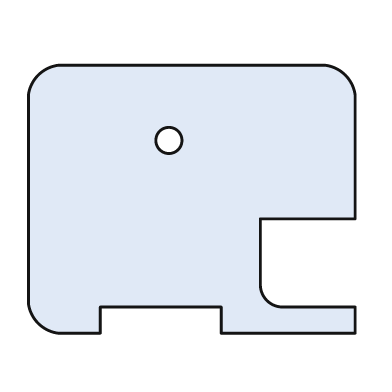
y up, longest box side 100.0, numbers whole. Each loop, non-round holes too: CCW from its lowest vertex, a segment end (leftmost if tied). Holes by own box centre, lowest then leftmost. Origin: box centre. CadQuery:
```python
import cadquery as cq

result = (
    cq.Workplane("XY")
    .moveTo(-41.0, -41.0)
    .lineTo(-28.0, -41.0)
    .lineTo(-28.0, -33.0)
    .lineTo(9.0, -33.0)
    .lineTo(9.0, -41.0)
    .lineTo(50.0, -41.0)
    .lineTo(50.0, -33.0)
    .lineTo(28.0, -33.0)
    .threePointArc((23.0, -31.0), (21.0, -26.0))
    .lineTo(21.0, -6.0)
    .lineTo(50.0, -6.0)
    .lineTo(50.0, 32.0)
    .threePointArc((47.0, 38.0), (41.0, 41.0))
    .lineTo(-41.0, 41.0)
    .threePointArc((-47.0, 38.0), (-50.0, 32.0))
    .lineTo(-50.0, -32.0)
    .threePointArc((-47.0, -38.0), (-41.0, -41.0))
    .close()
    .moveTo(-7.0, 18.0)
    .circle(4.0)
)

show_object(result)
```